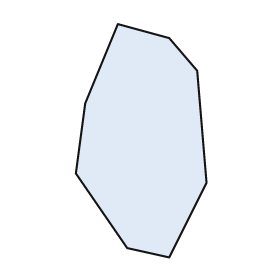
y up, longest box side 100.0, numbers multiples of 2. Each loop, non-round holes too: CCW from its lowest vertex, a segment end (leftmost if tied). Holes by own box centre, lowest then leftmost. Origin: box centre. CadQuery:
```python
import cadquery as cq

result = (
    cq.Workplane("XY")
    .moveTo(12.0, -50.0)
    .lineTo(28.0, -18.0)
    .lineTo(24.0, 30.0)
    .lineTo(12.0, 44.0)
    .lineTo(-10.0, 50.0)
    .lineTo(-24.0, 16.0)
    .lineTo(-28.0, -14.0)
    .lineTo(-6.0, -46.0)
    .close()
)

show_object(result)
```